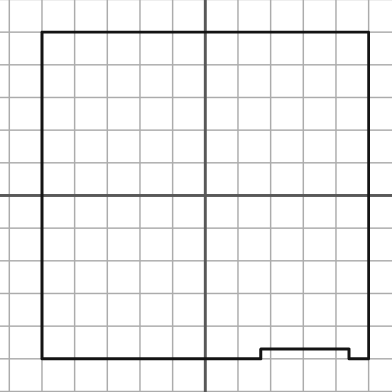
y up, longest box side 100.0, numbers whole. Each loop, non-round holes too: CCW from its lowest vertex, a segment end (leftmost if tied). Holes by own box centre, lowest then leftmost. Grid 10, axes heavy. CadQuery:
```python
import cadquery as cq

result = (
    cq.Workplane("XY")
    .moveTo(-50.0, -50.0)
    .lineTo(17.0, -50.0)
    .lineTo(17.0, -47.0)
    .lineTo(44.0, -47.0)
    .lineTo(44.0, -50.0)
    .lineTo(50.0, -50.0)
    .lineTo(50.0, 50.0)
    .lineTo(-50.0, 50.0)
    .close()
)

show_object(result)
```